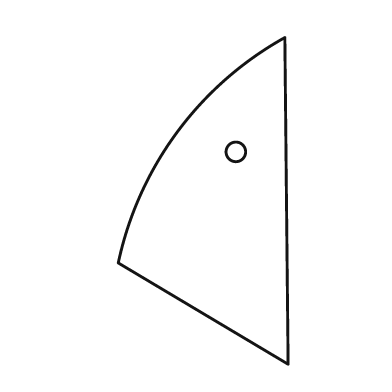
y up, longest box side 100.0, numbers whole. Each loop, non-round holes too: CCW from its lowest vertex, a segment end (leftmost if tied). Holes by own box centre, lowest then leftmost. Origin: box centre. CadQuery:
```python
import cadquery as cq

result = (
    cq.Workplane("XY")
    .moveTo(26.0, -50.0)
    .lineTo(25.0, 50.0)
    .threePointArc((-8.0, 21.0), (-26.0, -19.0))
    .close()
    .moveTo(10.0, 15.0)
    .circle(3.0)
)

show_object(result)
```